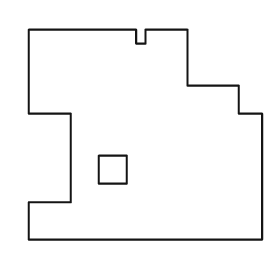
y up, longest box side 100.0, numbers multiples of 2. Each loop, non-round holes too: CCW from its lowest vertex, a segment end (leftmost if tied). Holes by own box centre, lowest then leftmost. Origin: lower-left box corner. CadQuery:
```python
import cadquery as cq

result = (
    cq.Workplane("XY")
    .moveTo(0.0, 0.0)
    .lineTo(100.0, 0.0)
    .lineTo(100.0, 54.0)
    .lineTo(90.0, 54.0)
    .lineTo(90.0, 66.0)
    .lineTo(68.0, 66.0)
    .lineTo(68.0, 90.0)
    .lineTo(50.0, 90.0)
    .lineTo(50.0, 84.0)
    .lineTo(46.0, 84.0)
    .lineTo(46.0, 90.0)
    .lineTo(0.0, 90.0)
    .lineTo(0.0, 54.0)
    .lineTo(18.0, 54.0)
    .lineTo(18.0, 16.0)
    .lineTo(0.0, 16.0)
    .close()
    .moveTo(30.0, 24.0)
    .lineTo(42.0, 24.0)
    .lineTo(42.0, 36.0)
    .lineTo(30.0, 36.0)
    .close()
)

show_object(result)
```